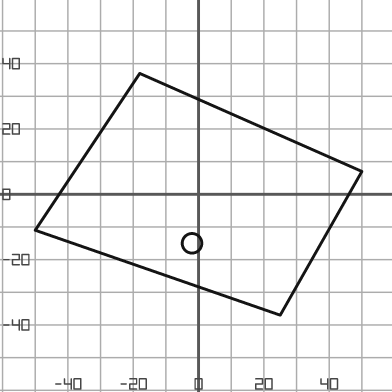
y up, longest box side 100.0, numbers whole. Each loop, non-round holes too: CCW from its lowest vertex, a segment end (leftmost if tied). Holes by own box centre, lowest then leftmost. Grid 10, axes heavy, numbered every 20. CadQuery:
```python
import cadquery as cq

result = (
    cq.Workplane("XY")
    .moveTo(25.0, -37.0)
    .lineTo(50.0, 7.0)
    .lineTo(-18.0, 37.0)
    .lineTo(-50.0, -11.0)
    .close()
    .moveTo(-2.0, -15.0)
    .circle(3.0)
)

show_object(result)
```